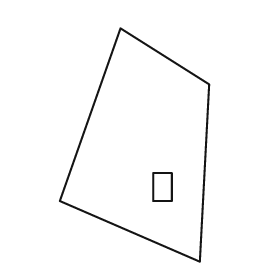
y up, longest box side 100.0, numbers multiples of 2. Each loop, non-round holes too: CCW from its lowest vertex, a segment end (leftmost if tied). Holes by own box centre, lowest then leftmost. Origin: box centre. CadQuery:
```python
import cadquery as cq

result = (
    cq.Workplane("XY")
    .moveTo(28.0, -50.0)
    .lineTo(32.0, 26.0)
    .lineTo(-6.0, 50.0)
    .lineTo(-32.0, -24.0)
    .close()
    .moveTo(8.0, -24.0)
    .lineTo(16.0, -24.0)
    .lineTo(16.0, -12.0)
    .lineTo(8.0, -12.0)
    .close()
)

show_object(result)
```